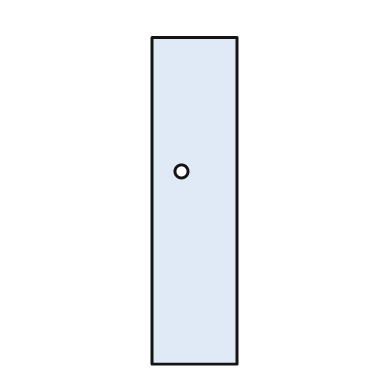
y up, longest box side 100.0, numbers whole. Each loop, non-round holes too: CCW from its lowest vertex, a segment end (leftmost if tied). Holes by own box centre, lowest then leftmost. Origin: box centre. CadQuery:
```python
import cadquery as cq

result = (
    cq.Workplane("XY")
    .moveTo(-13.0, -50.0)
    .lineTo(13.0, -50.0)
    .lineTo(13.0, 50.0)
    .lineTo(-13.0, 50.0)
    .close()
    .moveTo(-4.0, 9.0)
    .circle(2.0)
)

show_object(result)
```